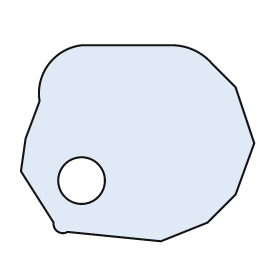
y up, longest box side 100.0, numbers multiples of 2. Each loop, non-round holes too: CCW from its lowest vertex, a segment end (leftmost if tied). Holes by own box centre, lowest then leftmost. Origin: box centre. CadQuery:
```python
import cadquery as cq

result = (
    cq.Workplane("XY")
    .moveTo(10.0, -42.0)
    .lineTo(30.0, -34.0)
    .lineTo(42.0, -22.0)
    .lineTo(50.0, 0.0)
    .lineTo(42.0, 24.0)
    .lineTo(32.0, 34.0)
    .threePointArc((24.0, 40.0), (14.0, 42.0))
    .lineTo(-24.0, 42.0)
    .threePointArc((-38.0, 34.0), (-42.0, 18.0))
    .lineTo(-48.0, 2.0)
    .lineTo(-50.0, -12.0)
    .lineTo(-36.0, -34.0)
    .threePointArc((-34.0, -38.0), (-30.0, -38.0))
    .close()
    .moveTo(-24.0, -16.0)
    .circle(10.0)
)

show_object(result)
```